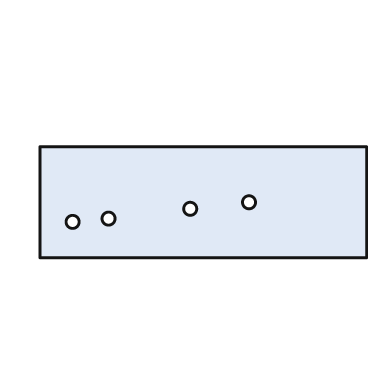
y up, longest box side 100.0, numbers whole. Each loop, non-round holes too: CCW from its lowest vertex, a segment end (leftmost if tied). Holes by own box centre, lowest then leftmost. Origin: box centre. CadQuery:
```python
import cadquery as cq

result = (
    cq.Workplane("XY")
    .moveTo(-50.0, -17.0)
    .lineTo(50.0, -17.0)
    .lineTo(50.0, 17.0)
    .lineTo(-50.0, 17.0)
    .close()
    .moveTo(-40.0, -6.0)
    .circle(2.0)
    .moveTo(-29.0, -5.0)
    .circle(2.0)
    .moveTo(-4.0, -2.0)
    .circle(2.0)
    .moveTo(14.0, 0.0)
    .circle(2.0)
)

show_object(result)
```